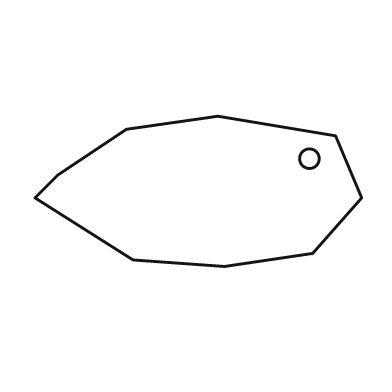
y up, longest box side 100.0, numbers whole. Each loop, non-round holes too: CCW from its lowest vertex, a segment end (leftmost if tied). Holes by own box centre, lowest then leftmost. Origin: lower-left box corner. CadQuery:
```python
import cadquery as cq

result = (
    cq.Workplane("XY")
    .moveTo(58.0, 0.0)
    .lineTo(85.0, 4.0)
    .lineTo(100.0, 21.0)
    .lineTo(92.0, 40.0)
    .lineTo(56.0, 46.0)
    .lineTo(28.0, 42.0)
    .lineTo(7.0, 28.0)
    .lineTo(0.0, 21.0)
    .lineTo(30.0, 2.0)
    .close()
    .moveTo(84.0, 33.0)
    .circle(3.0)
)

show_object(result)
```